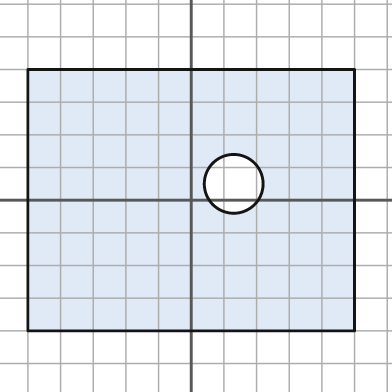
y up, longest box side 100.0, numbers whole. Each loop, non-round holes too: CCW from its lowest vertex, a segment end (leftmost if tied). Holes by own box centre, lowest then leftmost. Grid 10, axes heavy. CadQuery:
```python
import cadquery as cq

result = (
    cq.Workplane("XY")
    .moveTo(-50.0, -40.0)
    .lineTo(50.0, -40.0)
    .lineTo(50.0, 40.0)
    .lineTo(-50.0, 40.0)
    .close()
    .moveTo(13.0, 5.0)
    .circle(9.0)
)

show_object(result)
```